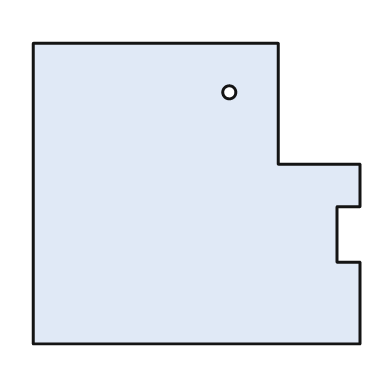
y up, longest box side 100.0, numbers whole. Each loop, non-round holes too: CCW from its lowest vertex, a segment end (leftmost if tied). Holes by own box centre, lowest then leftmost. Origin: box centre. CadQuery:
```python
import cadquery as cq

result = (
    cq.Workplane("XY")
    .moveTo(-50.0, -46.0)
    .lineTo(50.0, -46.0)
    .lineTo(50.0, -21.0)
    .lineTo(43.0, -21.0)
    .lineTo(43.0, -4.0)
    .lineTo(50.0, -4.0)
    .lineTo(50.0, 9.0)
    .lineTo(25.0, 9.0)
    .lineTo(25.0, 46.0)
    .lineTo(-50.0, 46.0)
    .close()
    .moveTo(10.0, 31.0)
    .circle(2.0)
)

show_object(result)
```